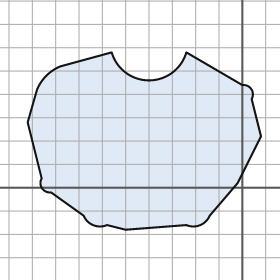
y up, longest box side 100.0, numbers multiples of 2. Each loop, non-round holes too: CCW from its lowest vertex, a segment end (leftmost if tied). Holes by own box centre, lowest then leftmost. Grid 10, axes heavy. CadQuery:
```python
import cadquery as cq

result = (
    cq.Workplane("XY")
    .moveTo(-50.0, -18.0)
    .lineTo(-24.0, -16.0)
    .threePointArc((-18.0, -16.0), (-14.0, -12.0))
    .lineTo(-2.0, 2.0)
    .lineTo(8.0, 22.0)
    .lineTo(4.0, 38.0)
    .threePointArc((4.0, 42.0), (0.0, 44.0))
    .lineTo(-24.0, 58.0)
    .threePointArc((-40.0, 46.0), (-56.0, 58.0))
    .lineTo(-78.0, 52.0)
    .threePointArc((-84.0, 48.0), (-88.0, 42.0))
    .lineTo(-92.0, 28.0)
    .lineTo(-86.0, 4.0)
    .threePointArc((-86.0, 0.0), (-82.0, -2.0))
    .lineTo(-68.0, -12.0)
    .threePointArc((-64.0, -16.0), (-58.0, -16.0))
    .close()
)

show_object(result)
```